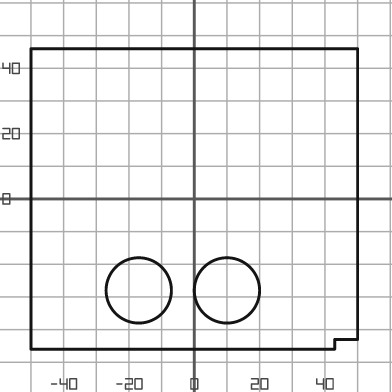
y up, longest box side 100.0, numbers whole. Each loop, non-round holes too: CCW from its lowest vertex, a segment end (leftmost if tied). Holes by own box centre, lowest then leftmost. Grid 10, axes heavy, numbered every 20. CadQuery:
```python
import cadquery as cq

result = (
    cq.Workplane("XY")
    .moveTo(-50.0, -46.0)
    .lineTo(43.0, -46.0)
    .lineTo(43.0, -43.0)
    .lineTo(50.0, -43.0)
    .lineTo(50.0, 46.0)
    .lineTo(-50.0, 46.0)
    .close()
    .moveTo(-17.0, -28.0)
    .circle(10.0)
    .moveTo(10.0, -28.0)
    .circle(10.0)
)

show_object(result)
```